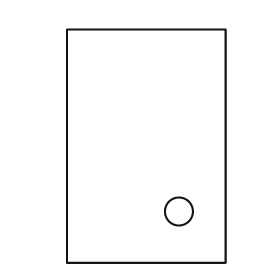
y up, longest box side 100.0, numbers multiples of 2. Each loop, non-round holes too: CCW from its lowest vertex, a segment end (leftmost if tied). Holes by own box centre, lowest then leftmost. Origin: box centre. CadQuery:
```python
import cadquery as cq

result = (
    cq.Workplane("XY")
    .moveTo(-34.0, -50.0)
    .lineTo(34.0, -50.0)
    .lineTo(34.0, 50.0)
    .lineTo(-34.0, 50.0)
    .close()
    .moveTo(14.0, -28.0)
    .circle(6.0)
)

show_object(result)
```